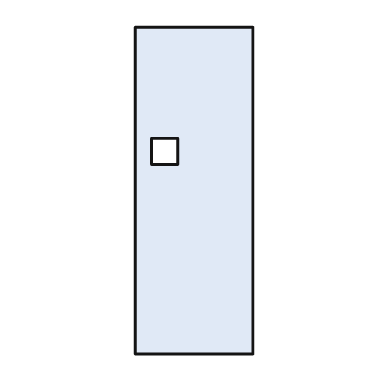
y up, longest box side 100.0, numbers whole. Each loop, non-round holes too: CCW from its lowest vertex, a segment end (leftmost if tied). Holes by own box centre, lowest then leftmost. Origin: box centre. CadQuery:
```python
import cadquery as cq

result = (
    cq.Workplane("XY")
    .moveTo(-18.0, -50.0)
    .lineTo(18.0, -50.0)
    .lineTo(18.0, 50.0)
    .lineTo(-18.0, 50.0)
    .close()
    .moveTo(-13.0, 8.0)
    .lineTo(-5.0, 8.0)
    .lineTo(-5.0, 16.0)
    .lineTo(-13.0, 16.0)
    .close()
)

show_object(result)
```